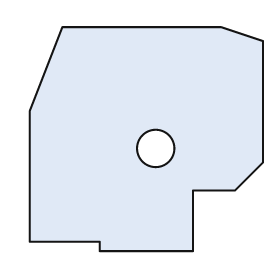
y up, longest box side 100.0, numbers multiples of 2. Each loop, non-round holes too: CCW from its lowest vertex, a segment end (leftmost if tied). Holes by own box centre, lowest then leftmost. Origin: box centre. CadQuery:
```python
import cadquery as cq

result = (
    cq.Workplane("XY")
    .moveTo(-20.0, -48.0)
    .lineTo(20.0, -48.0)
    .lineTo(20.0, -22.0)
    .lineTo(38.0, -22.0)
    .lineTo(50.0, -10.0)
    .lineTo(50.0, 42.0)
    .lineTo(32.0, 48.0)
    .lineTo(-36.0, 48.0)
    .lineTo(-50.0, 12.0)
    .lineTo(-50.0, -44.0)
    .lineTo(-20.0, -44.0)
    .close()
    .moveTo(4.0, -4.0)
    .circle(8.0)
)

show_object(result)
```